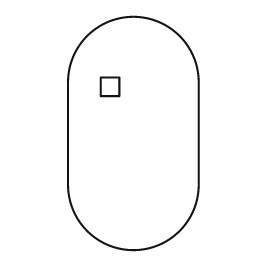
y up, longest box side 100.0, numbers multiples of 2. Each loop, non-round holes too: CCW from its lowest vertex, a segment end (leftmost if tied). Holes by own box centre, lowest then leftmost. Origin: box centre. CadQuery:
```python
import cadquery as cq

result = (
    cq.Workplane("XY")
    .moveTo(-28.0, -22.0)
    .threePointArc((0.0, -50.0), (28.0, -22.0))
    .lineTo(28.0, 22.0)
    .threePointArc((0.0, 50.0), (-28.0, 22.0))
    .close()
    .moveTo(-14.0, 16.0)
    .lineTo(-6.0, 16.0)
    .lineTo(-6.0, 24.0)
    .lineTo(-14.0, 24.0)
    .close()
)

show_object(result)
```